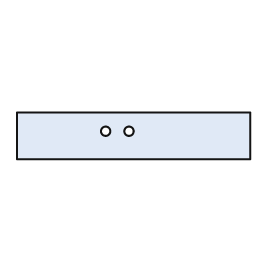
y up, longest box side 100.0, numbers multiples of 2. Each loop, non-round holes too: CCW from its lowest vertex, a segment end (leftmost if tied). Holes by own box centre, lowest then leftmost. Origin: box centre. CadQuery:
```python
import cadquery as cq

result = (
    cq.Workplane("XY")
    .moveTo(-50.0, -10.0)
    .lineTo(50.0, -10.0)
    .lineTo(50.0, 10.0)
    .lineTo(-50.0, 10.0)
    .close()
    .moveTo(-12.0, 2.0)
    .circle(2.0)
    .moveTo(-2.0, 2.0)
    .circle(2.0)
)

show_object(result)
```